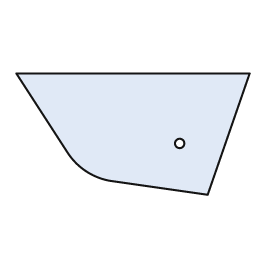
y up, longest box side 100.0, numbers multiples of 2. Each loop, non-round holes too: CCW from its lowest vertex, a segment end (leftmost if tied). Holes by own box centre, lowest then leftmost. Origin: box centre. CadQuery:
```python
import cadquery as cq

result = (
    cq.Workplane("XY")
    .moveTo(32.0, -26.0)
    .lineTo(50.0, 26.0)
    .lineTo(-50.0, 26.0)
    .lineTo(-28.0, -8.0)
    .threePointArc((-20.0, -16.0), (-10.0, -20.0))
    .close()
    .moveTo(20.0, -4.0)
    .circle(2.0)
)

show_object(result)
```